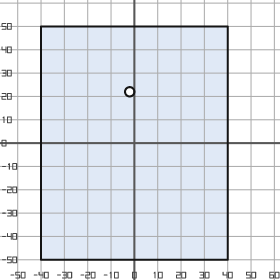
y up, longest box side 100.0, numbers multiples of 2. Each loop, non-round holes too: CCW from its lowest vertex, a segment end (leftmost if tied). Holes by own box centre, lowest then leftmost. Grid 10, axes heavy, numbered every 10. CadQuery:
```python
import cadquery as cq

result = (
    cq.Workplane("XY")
    .moveTo(-40.0, -50.0)
    .lineTo(40.0, -50.0)
    .lineTo(40.0, 50.0)
    .lineTo(-40.0, 50.0)
    .close()
    .moveTo(-2.0, 22.0)
    .circle(2.0)
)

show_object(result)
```